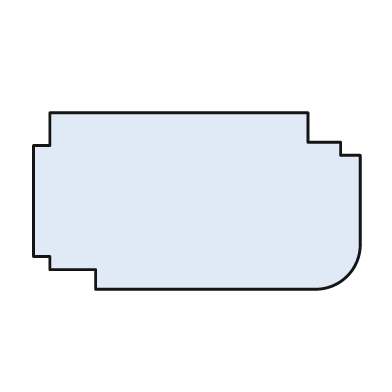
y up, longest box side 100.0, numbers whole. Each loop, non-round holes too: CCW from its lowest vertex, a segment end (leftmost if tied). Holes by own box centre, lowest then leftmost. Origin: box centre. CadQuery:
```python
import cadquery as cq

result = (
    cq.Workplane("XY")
    .moveTo(-31.0, -27.0)
    .lineTo(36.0, -27.0)
    .threePointArc((46.0, -23.0), (50.0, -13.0))
    .lineTo(50.0, 14.0)
    .lineTo(44.0, 14.0)
    .lineTo(44.0, 18.0)
    .lineTo(34.0, 18.0)
    .lineTo(34.0, 27.0)
    .lineTo(-45.0, 27.0)
    .lineTo(-45.0, 17.0)
    .lineTo(-50.0, 17.0)
    .lineTo(-50.0, -17.0)
    .lineTo(-45.0, -17.0)
    .lineTo(-45.0, -21.0)
    .lineTo(-31.0, -21.0)
    .close()
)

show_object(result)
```